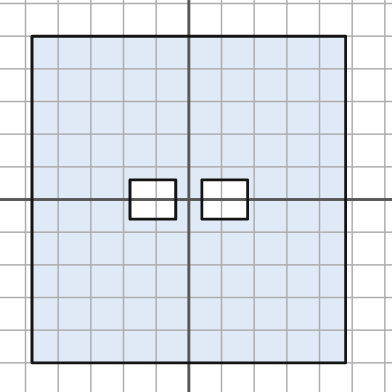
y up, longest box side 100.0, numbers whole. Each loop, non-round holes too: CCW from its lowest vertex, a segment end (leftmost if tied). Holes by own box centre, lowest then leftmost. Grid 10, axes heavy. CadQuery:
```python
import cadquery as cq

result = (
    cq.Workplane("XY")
    .moveTo(-48.0, -50.0)
    .lineTo(48.0, -50.0)
    .lineTo(48.0, 50.0)
    .lineTo(-48.0, 50.0)
    .close()
    .moveTo(-18.0, -6.0)
    .lineTo(-4.0, -6.0)
    .lineTo(-4.0, 6.0)
    .lineTo(-18.0, 6.0)
    .close()
    .moveTo(4.0, -6.0)
    .lineTo(18.0, -6.0)
    .lineTo(18.0, 6.0)
    .lineTo(4.0, 6.0)
    .close()
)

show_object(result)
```